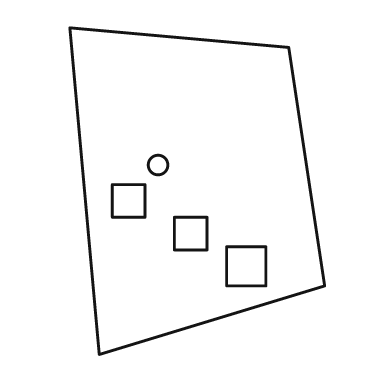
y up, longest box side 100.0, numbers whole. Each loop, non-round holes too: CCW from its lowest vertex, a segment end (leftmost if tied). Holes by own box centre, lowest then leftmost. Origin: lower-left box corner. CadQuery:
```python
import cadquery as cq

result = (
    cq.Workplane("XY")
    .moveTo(9.0, 0.0)
    .lineTo(78.0, 21.0)
    .lineTo(67.0, 94.0)
    .lineTo(0.0, 100.0)
    .close()
    .moveTo(48.0, 21.0)
    .lineTo(60.0, 21.0)
    .lineTo(60.0, 33.0)
    .lineTo(48.0, 33.0)
    .close()
    .moveTo(32.0, 32.0)
    .lineTo(42.0, 32.0)
    .lineTo(42.0, 42.0)
    .lineTo(32.0, 42.0)
    .close()
    .moveTo(13.0, 42.0)
    .lineTo(23.0, 42.0)
    .lineTo(23.0, 52.0)
    .lineTo(13.0, 52.0)
    .close()
    .moveTo(27.0, 58.0)
    .circle(3.0)
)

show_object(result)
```